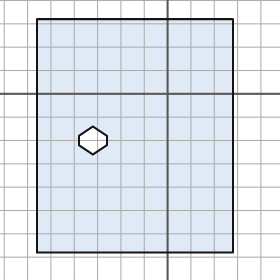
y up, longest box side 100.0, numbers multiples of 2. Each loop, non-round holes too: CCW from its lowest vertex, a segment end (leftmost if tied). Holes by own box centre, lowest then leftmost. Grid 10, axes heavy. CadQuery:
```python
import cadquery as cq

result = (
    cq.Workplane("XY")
    .moveTo(-56.0, -68.0)
    .lineTo(28.0, -68.0)
    .lineTo(28.0, 32.0)
    .lineTo(-56.0, 32.0)
    .close()
    .moveTo(-32.0, -26.0)
    .lineTo(-26.0, -22.0)
    .lineTo(-26.0, -18.0)
    .lineTo(-32.0, -14.0)
    .lineTo(-38.0, -18.0)
    .lineTo(-38.0, -22.0)
    .close()
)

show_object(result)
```